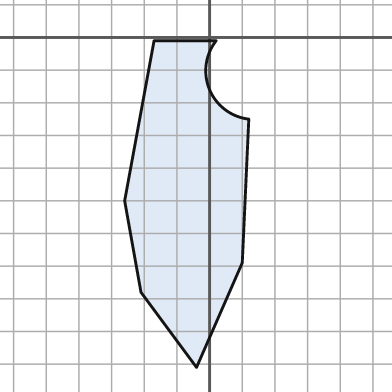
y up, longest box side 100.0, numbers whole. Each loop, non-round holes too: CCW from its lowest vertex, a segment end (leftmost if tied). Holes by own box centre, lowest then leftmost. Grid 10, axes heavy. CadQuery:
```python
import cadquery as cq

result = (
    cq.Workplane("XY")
    .moveTo(-4.0, -101.0)
    .lineTo(10.0, -69.0)
    .lineTo(12.0, -25.0)
    .threePointArc((0.0, -16.0), (2.0, -1.0))
    .lineTo(-17.0, -1.0)
    .lineTo(-26.0, -50.0)
    .lineTo(-21.0, -78.0)
    .close()
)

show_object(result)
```